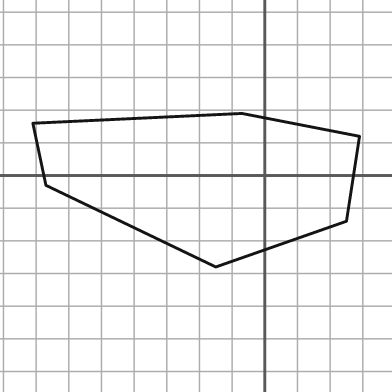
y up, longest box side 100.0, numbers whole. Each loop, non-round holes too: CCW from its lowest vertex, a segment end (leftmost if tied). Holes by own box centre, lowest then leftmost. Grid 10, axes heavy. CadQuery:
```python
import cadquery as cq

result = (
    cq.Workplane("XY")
    .moveTo(-15.0, -28.0)
    .lineTo(25.0, -14.0)
    .lineTo(29.0, 12.0)
    .lineTo(-7.0, 19.0)
    .lineTo(-71.0, 16.0)
    .lineTo(-67.0, -3.0)
    .close()
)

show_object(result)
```